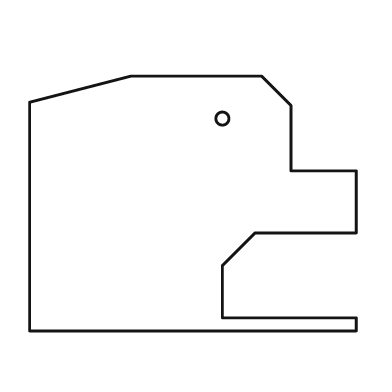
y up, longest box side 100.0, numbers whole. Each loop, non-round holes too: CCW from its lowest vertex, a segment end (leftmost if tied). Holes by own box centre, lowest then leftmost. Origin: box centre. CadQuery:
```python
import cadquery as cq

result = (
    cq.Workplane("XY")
    .moveTo(-50.0, -39.0)
    .lineTo(50.0, -39.0)
    .lineTo(50.0, -35.0)
    .lineTo(9.0, -35.0)
    .lineTo(9.0, -19.0)
    .lineTo(19.0, -9.0)
    .lineTo(50.0, -9.0)
    .lineTo(50.0, 10.0)
    .lineTo(30.0, 10.0)
    .lineTo(30.0, 30.0)
    .lineTo(21.0, 39.0)
    .lineTo(-19.0, 39.0)
    .lineTo(-50.0, 31.0)
    .close()
    .moveTo(9.0, 26.0)
    .circle(2.0)
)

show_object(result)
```